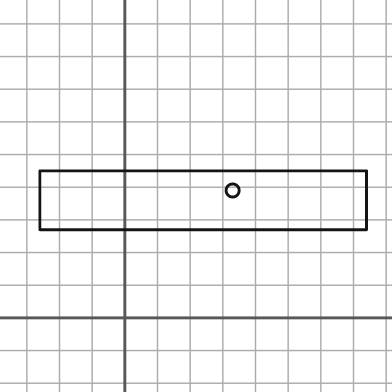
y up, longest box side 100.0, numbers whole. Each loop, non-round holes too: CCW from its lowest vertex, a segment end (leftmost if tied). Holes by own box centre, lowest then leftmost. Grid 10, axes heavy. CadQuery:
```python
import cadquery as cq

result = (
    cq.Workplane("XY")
    .moveTo(-26.0, 27.0)
    .lineTo(74.0, 27.0)
    .lineTo(74.0, 45.0)
    .lineTo(-26.0, 45.0)
    .close()
    .moveTo(33.0, 39.0)
    .circle(2.0)
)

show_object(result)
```